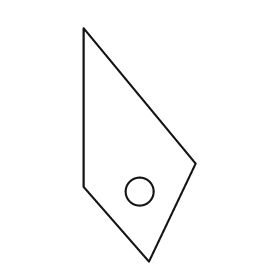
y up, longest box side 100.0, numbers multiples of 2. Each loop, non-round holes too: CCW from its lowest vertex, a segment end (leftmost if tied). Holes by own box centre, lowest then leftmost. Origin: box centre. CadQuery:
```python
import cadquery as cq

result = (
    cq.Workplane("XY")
    .moveTo(4.0, -50.0)
    .lineTo(24.0, -8.0)
    .lineTo(-24.0, 50.0)
    .lineTo(-24.0, -18.0)
    .close()
    .moveTo(0.0, -20.0)
    .circle(6.0)
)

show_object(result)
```